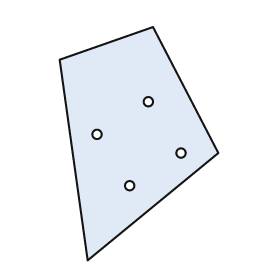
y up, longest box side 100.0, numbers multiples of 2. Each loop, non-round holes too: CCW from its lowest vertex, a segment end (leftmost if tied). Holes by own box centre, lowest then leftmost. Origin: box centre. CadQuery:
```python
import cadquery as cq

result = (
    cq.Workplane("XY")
    .moveTo(-22.0, -50.0)
    .lineTo(34.0, -4.0)
    .lineTo(6.0, 50.0)
    .lineTo(-34.0, 36.0)
    .close()
    .moveTo(-4.0, -18.0)
    .circle(2.0)
    .moveTo(18.0, -4.0)
    .circle(2.0)
    .moveTo(-18.0, 4.0)
    .circle(2.0)
    .moveTo(4.0, 18.0)
    .circle(2.0)
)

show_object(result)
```